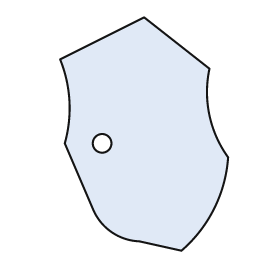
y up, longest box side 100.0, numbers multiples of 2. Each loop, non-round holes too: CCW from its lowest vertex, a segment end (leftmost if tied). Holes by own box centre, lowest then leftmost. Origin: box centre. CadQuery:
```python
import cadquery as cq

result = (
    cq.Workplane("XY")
    .moveTo(16.0, -50.0)
    .threePointArc((30.0, -32.0), (36.0, -10.0))
    .threePointArc((28.0, 8.0), (28.0, 28.0))
    .lineTo(0.0, 50.0)
    .lineTo(-36.0, 32.0)
    .threePointArc((-32.0, 14.0), (-34.0, -4.0))
    .lineTo(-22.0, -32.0)
    .threePointArc((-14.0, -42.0), (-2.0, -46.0))
    .close()
    .moveTo(-18.0, -4.0)
    .circle(4.0)
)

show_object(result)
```